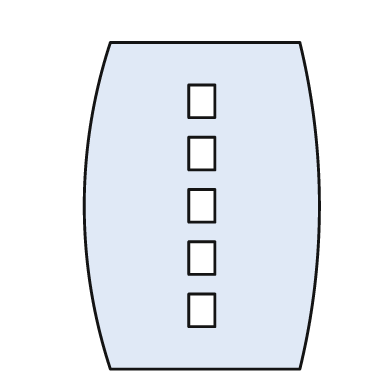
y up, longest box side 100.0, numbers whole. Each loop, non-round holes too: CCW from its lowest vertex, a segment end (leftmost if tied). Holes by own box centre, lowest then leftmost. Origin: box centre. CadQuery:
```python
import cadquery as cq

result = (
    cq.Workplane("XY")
    .moveTo(-28.0, -50.0)
    .lineTo(30.0, -50.0)
    .threePointArc((36.0, 0.0), (30.0, 50.0))
    .lineTo(-28.0, 50.0)
    .threePointArc((-36.0, 0.0), (-28.0, -50.0))
    .close()
    .moveTo(-4.0, -37.0)
    .lineTo(4.0, -37.0)
    .lineTo(4.0, -27.0)
    .lineTo(-4.0, -27.0)
    .close()
    .moveTo(-4.0, -21.0)
    .lineTo(4.0, -21.0)
    .lineTo(4.0, -11.0)
    .lineTo(-4.0, -11.0)
    .close()
    .moveTo(-4.0, -5.0)
    .lineTo(4.0, -5.0)
    .lineTo(4.0, 5.0)
    .lineTo(-4.0, 5.0)
    .close()
    .moveTo(-4.0, 11.0)
    .lineTo(4.0, 11.0)
    .lineTo(4.0, 21.0)
    .lineTo(-4.0, 21.0)
    .close()
    .moveTo(-4.0, 27.0)
    .lineTo(4.0, 27.0)
    .lineTo(4.0, 37.0)
    .lineTo(-4.0, 37.0)
    .close()
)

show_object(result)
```